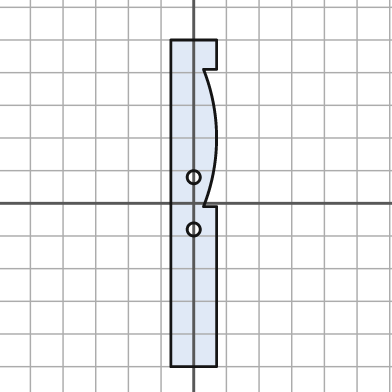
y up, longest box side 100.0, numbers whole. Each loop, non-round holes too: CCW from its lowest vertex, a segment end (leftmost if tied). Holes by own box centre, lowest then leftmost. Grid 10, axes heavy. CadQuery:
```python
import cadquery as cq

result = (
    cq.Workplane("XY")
    .moveTo(-7.0, -50.0)
    .lineTo(7.0, -50.0)
    .lineTo(7.0, -1.0)
    .lineTo(3.0, -1.0)
    .threePointArc((7.0, 20.0), (3.0, 41.0))
    .lineTo(7.0, 41.0)
    .lineTo(7.0, 50.0)
    .lineTo(-7.0, 50.0)
    .close()
    .moveTo(0.0, -8.0)
    .circle(2.0)
    .moveTo(0.0, 8.0)
    .circle(2.0)
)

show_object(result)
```